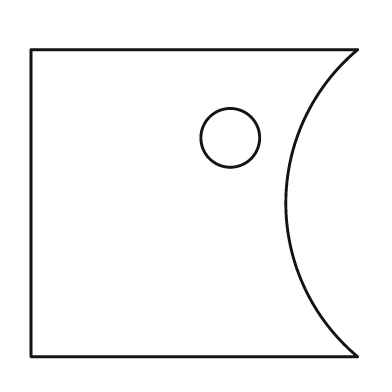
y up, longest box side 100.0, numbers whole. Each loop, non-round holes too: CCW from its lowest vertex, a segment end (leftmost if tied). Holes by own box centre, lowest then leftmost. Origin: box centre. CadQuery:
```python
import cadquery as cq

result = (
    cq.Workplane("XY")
    .moveTo(-50.0, -47.0)
    .lineTo(50.0, -47.0)
    .threePointArc((28.0, 0.0), (50.0, 47.0))
    .lineTo(-50.0, 47.0)
    .close()
    .moveTo(11.0, 20.0)
    .circle(9.0)
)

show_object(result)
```